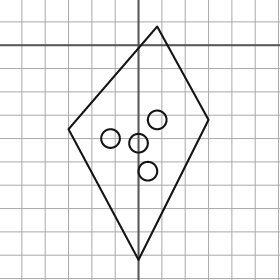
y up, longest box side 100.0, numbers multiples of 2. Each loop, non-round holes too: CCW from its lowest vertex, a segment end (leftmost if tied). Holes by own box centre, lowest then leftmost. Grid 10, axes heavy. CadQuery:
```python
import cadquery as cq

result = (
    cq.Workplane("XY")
    .moveTo(0.0, -92.0)
    .lineTo(30.0, -32.0)
    .lineTo(8.0, 8.0)
    .lineTo(-30.0, -36.0)
    .close()
    .moveTo(4.0, -54.0)
    .circle(4.0)
    .moveTo(0.0, -42.0)
    .circle(4.0)
    .moveTo(-12.0, -40.0)
    .circle(4.0)
    .moveTo(8.0, -32.0)
    .circle(4.0)
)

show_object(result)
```